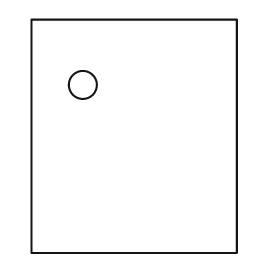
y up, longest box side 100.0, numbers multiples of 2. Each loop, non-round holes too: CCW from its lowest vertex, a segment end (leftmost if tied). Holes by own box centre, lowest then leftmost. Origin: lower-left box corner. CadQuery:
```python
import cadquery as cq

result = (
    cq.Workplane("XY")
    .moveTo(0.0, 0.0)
    .lineTo(88.0, 0.0)
    .lineTo(88.0, 100.0)
    .lineTo(0.0, 100.0)
    .close()
    .moveTo(22.0, 72.0)
    .circle(6.0)
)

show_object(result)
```